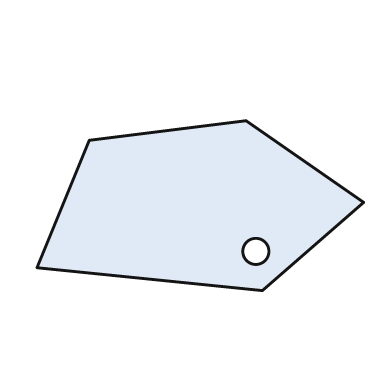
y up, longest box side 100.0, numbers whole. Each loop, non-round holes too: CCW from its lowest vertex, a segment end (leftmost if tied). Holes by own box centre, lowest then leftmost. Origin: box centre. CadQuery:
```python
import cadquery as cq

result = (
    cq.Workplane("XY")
    .moveTo(19.0, -26.0)
    .lineTo(50.0, 1.0)
    .lineTo(14.0, 26.0)
    .lineTo(-34.0, 20.0)
    .lineTo(-50.0, -19.0)
    .close()
    .moveTo(17.0, -14.0)
    .circle(4.0)
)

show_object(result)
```